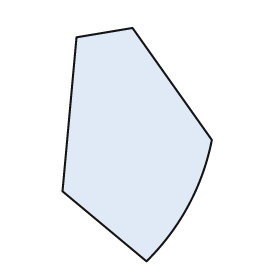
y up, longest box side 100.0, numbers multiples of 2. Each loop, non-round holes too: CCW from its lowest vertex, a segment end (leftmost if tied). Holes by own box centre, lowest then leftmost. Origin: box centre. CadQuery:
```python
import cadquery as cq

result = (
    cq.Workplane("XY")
    .moveTo(4.0, -50.0)
    .threePointArc((22.0, -26.0), (32.0, 2.0))
    .lineTo(-2.0, 50.0)
    .lineTo(-26.0, 46.0)
    .lineTo(-32.0, -20.0)
    .close()
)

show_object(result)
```